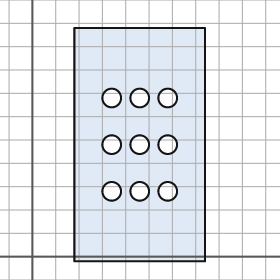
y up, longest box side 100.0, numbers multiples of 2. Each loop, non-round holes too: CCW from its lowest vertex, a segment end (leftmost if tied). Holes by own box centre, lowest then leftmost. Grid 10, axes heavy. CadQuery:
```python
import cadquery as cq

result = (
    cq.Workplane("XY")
    .moveTo(18.0, -2.0)
    .lineTo(74.0, -2.0)
    .lineTo(74.0, 98.0)
    .lineTo(18.0, 98.0)
    .close()
    .moveTo(34.0, 28.0)
    .circle(4.0)
    .moveTo(46.0, 28.0)
    .circle(4.0)
    .moveTo(58.0, 28.0)
    .circle(4.0)
    .moveTo(34.0, 48.0)
    .circle(4.0)
    .moveTo(46.0, 48.0)
    .circle(4.0)
    .moveTo(58.0, 48.0)
    .circle(4.0)
    .moveTo(34.0, 68.0)
    .circle(4.0)
    .moveTo(46.0, 68.0)
    .circle(4.0)
    .moveTo(58.0, 68.0)
    .circle(4.0)
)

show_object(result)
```